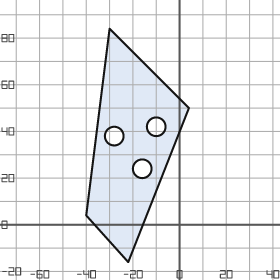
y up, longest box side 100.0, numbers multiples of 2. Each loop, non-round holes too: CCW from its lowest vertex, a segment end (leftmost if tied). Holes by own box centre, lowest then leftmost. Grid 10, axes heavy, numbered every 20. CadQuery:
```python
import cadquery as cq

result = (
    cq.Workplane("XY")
    .moveTo(-22.0, -16.0)
    .lineTo(4.0, 50.0)
    .lineTo(-30.0, 84.0)
    .lineTo(-40.0, 4.0)
    .close()
    .moveTo(-16.0, 24.0)
    .circle(4.0)
    .moveTo(-28.0, 38.0)
    .circle(4.0)
    .moveTo(-10.0, 42.0)
    .circle(4.0)
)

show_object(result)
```